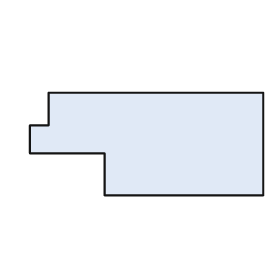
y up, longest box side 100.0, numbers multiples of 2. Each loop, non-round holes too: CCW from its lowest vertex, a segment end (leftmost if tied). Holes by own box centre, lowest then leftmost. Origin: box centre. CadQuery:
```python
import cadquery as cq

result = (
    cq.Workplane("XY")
    .moveTo(-18.0, -22.0)
    .lineTo(50.0, -22.0)
    .lineTo(50.0, 22.0)
    .lineTo(-42.0, 22.0)
    .lineTo(-42.0, 8.0)
    .lineTo(-50.0, 8.0)
    .lineTo(-50.0, -4.0)
    .lineTo(-18.0, -4.0)
    .close()
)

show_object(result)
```